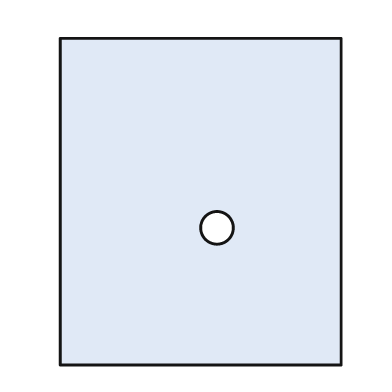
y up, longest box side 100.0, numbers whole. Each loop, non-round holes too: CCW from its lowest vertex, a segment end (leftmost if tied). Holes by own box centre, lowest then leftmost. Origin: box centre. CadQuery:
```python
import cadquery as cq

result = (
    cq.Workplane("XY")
    .moveTo(-43.0, -50.0)
    .lineTo(43.0, -50.0)
    .lineTo(43.0, 50.0)
    .lineTo(-43.0, 50.0)
    .close()
    .moveTo(5.0, -8.0)
    .circle(5.0)
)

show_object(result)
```